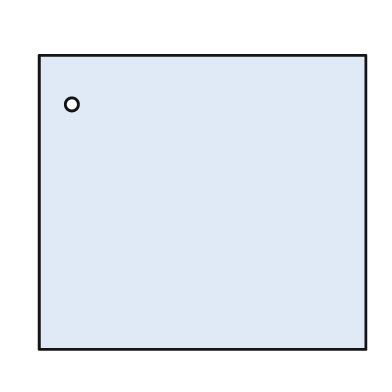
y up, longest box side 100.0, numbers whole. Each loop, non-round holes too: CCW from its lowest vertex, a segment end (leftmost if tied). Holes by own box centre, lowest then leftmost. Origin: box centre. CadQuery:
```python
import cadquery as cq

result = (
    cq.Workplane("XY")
    .moveTo(-50.0, -45.0)
    .lineTo(50.0, -45.0)
    .lineTo(50.0, 45.0)
    .lineTo(-50.0, 45.0)
    .close()
    .moveTo(-40.0, 30.0)
    .circle(2.0)
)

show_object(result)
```